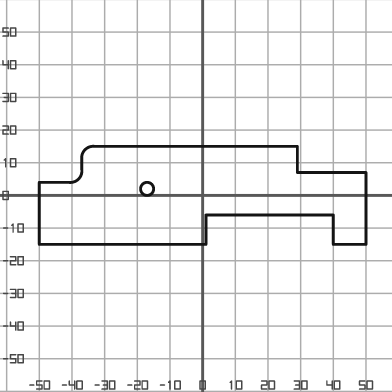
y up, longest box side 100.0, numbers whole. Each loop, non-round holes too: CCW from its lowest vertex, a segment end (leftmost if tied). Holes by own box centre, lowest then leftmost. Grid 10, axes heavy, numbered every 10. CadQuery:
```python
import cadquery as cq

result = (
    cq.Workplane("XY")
    .moveTo(-50.0, -15.0)
    .lineTo(1.0, -15.0)
    .lineTo(1.0, -6.0)
    .lineTo(40.0, -6.0)
    .lineTo(40.0, -15.0)
    .lineTo(50.0, -15.0)
    .lineTo(50.0, 7.0)
    .lineTo(29.0, 7.0)
    .lineTo(29.0, 15.0)
    .lineTo(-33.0, 15.0)
    .threePointArc((-36.0, 14.0), (-37.0, 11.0))
    .lineTo(-37.0, 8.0)
    .threePointArc((-38.0, 5.0), (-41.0, 4.0))
    .lineTo(-50.0, 4.0)
    .close()
    .moveTo(-17.0, 2.0)
    .circle(2.0)
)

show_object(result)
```